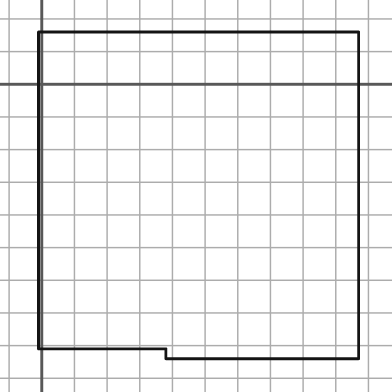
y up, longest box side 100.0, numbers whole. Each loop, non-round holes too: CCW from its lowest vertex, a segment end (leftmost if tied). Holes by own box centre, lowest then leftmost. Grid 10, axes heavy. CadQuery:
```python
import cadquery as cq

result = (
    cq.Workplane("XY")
    .moveTo(38.0, -84.0)
    .lineTo(97.0, -84.0)
    .lineTo(97.0, 16.0)
    .lineTo(-1.0, 16.0)
    .lineTo(-1.0, -81.0)
    .lineTo(38.0, -81.0)
    .close()
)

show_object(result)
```